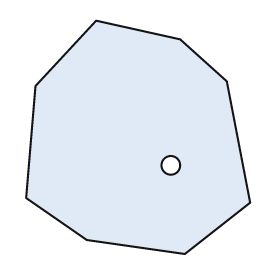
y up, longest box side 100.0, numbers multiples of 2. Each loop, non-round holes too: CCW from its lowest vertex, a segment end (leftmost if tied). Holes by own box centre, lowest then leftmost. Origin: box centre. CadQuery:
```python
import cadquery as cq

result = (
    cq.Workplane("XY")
    .moveTo(20.0, -50.0)
    .lineTo(48.0, -28.0)
    .lineTo(38.0, 24.0)
    .lineTo(18.0, 42.0)
    .lineTo(-18.0, 50.0)
    .lineTo(-44.0, 22.0)
    .lineTo(-48.0, -26.0)
    .lineTo(-22.0, -44.0)
    .close()
    .moveTo(14.0, -12.0)
    .circle(4.0)
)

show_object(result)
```